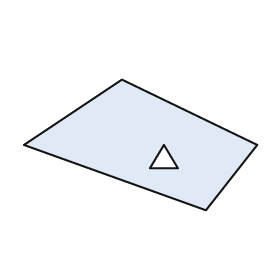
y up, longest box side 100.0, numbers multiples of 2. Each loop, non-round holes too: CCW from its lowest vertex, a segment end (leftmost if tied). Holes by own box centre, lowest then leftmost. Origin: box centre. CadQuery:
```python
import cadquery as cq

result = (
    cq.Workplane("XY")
    .moveTo(28.0, -28.0)
    .lineTo(50.0, 0.0)
    .lineTo(-8.0, 28.0)
    .lineTo(-50.0, 0.0)
    .close()
    .moveTo(4.0, -10.0)
    .lineTo(16.0, -10.0)
    .lineTo(10.0, 0.0)
    .close()
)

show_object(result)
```